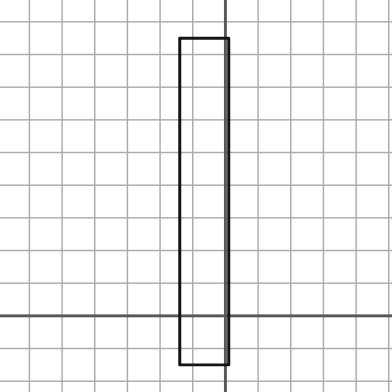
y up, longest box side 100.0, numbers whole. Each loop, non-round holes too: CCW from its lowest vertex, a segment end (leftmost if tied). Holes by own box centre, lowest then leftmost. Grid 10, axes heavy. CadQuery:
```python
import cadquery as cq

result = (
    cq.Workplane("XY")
    .moveTo(-14.0, -15.0)
    .lineTo(1.0, -15.0)
    .lineTo(1.0, 85.0)
    .lineTo(-14.0, 85.0)
    .close()
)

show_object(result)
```